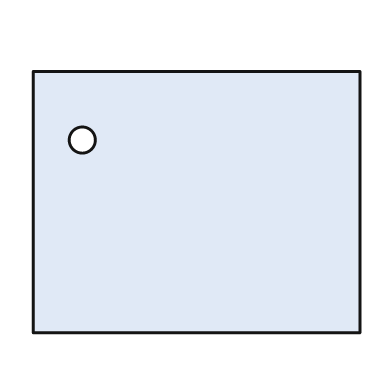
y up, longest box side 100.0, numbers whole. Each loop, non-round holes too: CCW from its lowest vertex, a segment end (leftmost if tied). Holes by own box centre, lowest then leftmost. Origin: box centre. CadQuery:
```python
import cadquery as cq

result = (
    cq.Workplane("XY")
    .moveTo(-50.0, -40.0)
    .lineTo(50.0, -40.0)
    .lineTo(50.0, 40.0)
    .lineTo(-50.0, 40.0)
    .close()
    .moveTo(-35.0, 19.0)
    .circle(4.0)
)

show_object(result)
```